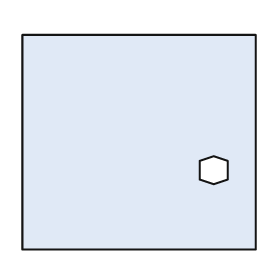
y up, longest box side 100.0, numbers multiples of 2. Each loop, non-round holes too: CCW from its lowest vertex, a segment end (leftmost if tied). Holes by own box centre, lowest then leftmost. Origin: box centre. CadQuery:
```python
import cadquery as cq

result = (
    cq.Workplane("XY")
    .moveTo(-50.0, -46.0)
    .lineTo(50.0, -46.0)
    .lineTo(50.0, 46.0)
    .lineTo(-50.0, 46.0)
    .close()
    .moveTo(32.0, -18.0)
    .lineTo(38.0, -16.0)
    .lineTo(38.0, -8.0)
    .lineTo(32.0, -6.0)
    .lineTo(26.0, -8.0)
    .lineTo(26.0, -16.0)
    .close()
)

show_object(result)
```